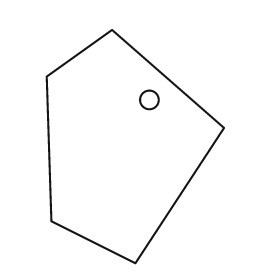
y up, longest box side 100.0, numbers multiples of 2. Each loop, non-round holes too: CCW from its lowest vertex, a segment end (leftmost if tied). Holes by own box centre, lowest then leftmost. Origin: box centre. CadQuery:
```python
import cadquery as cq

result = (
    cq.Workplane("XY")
    .moveTo(0.0, -50.0)
    .lineTo(38.0, 8.0)
    .lineTo(-10.0, 50.0)
    .lineTo(-38.0, 30.0)
    .lineTo(-36.0, -32.0)
    .close()
    .moveTo(6.0, 20.0)
    .circle(4.0)
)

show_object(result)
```